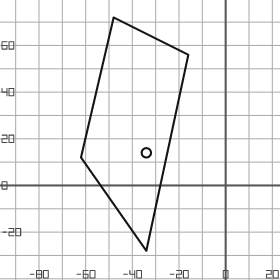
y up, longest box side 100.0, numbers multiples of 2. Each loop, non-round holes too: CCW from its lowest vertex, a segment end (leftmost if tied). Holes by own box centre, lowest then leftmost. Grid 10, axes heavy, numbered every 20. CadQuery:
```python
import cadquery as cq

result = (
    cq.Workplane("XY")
    .moveTo(-34.0, -28.0)
    .lineTo(-16.0, 56.0)
    .lineTo(-48.0, 72.0)
    .lineTo(-62.0, 12.0)
    .close()
    .moveTo(-34.0, 14.0)
    .circle(2.0)
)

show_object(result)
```